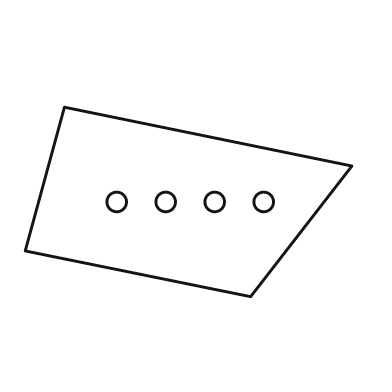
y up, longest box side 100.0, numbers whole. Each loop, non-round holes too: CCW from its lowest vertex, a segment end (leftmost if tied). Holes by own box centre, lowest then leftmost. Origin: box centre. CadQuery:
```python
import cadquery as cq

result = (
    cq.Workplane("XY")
    .moveTo(19.0, -29.0)
    .lineTo(50.0, 11.0)
    .lineTo(-38.0, 29.0)
    .lineTo(-50.0, -15.0)
    .close()
    .moveTo(-22.0, 0.0)
    .circle(3.0)
    .moveTo(-7.0, 0.0)
    .circle(3.0)
    .moveTo(8.0, 0.0)
    .circle(3.0)
    .moveTo(23.0, 0.0)
    .circle(3.0)
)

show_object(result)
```